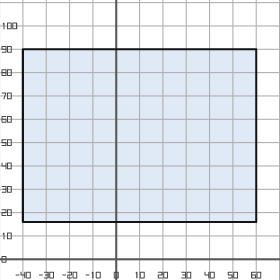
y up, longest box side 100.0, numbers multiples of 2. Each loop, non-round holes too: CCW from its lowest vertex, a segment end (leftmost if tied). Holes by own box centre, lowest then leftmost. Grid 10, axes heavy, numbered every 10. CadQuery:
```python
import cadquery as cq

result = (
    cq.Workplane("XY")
    .moveTo(-40.0, 16.0)
    .lineTo(60.0, 16.0)
    .lineTo(60.0, 90.0)
    .lineTo(-40.0, 90.0)
    .close()
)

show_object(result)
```